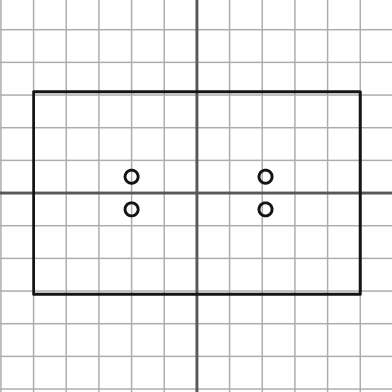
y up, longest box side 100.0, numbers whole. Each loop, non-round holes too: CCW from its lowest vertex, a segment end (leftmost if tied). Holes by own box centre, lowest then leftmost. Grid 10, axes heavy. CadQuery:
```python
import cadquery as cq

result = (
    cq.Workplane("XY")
    .moveTo(-50.0, -31.0)
    .lineTo(50.0, -31.0)
    .lineTo(50.0, 31.0)
    .lineTo(-50.0, 31.0)
    .close()
    .moveTo(-20.0, -5.0)
    .circle(2.0)
    .moveTo(21.0, -5.0)
    .circle(2.0)
    .moveTo(-20.0, 5.0)
    .circle(2.0)
    .moveTo(21.0, 5.0)
    .circle(2.0)
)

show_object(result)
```